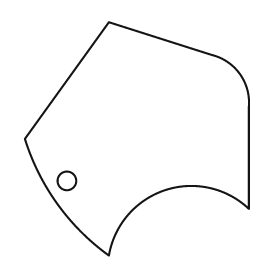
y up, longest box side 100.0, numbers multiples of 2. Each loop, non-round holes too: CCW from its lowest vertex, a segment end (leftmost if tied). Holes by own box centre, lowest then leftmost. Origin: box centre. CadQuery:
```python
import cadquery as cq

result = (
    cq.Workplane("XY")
    .moveTo(-12.0, -50.0)
    .threePointArc((12.0, -22.0), (48.0, -30.0))
    .lineTo(48.0, 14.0)
    .threePointArc((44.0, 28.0), (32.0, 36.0))
    .lineTo(-12.0, 50.0)
    .lineTo(-48.0, 0.0)
    .threePointArc((-34.0, -28.0), (-12.0, -50.0))
    .close()
    .moveTo(-30.0, -18.0)
    .circle(4.0)
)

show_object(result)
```